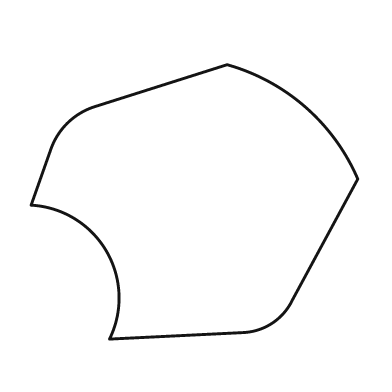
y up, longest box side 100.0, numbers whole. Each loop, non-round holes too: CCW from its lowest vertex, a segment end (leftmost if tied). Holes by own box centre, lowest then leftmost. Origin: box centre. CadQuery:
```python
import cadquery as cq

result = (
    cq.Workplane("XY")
    .moveTo(-26.0, -42.0)
    .lineTo(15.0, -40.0)
    .threePointArc((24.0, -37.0), (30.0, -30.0))
    .lineTo(50.0, 7.0)
    .threePointArc((34.0, 29.0), (10.0, 42.0))
    .lineTo(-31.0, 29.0)
    .threePointArc((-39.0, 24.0), (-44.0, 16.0))
    .lineTo(-50.0, -1.0)
    .threePointArc((-27.0, -15.0), (-26.0, -42.0))
    .close()
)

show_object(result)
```